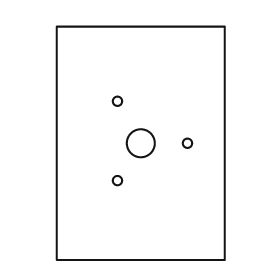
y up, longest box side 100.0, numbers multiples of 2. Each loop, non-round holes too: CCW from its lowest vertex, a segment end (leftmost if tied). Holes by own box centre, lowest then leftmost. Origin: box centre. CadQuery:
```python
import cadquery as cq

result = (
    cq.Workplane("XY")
    .moveTo(-36.0, -50.0)
    .lineTo(36.0, -50.0)
    .lineTo(36.0, 50.0)
    .lineTo(-36.0, 50.0)
    .close()
    .moveTo(-10.0, -16.0)
    .circle(2.0)
    .moveTo(0.0, 0.0)
    .circle(6.0)
    .moveTo(20.0, 0.0)
    .circle(2.0)
    .moveTo(-10.0, 18.0)
    .circle(2.0)
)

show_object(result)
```